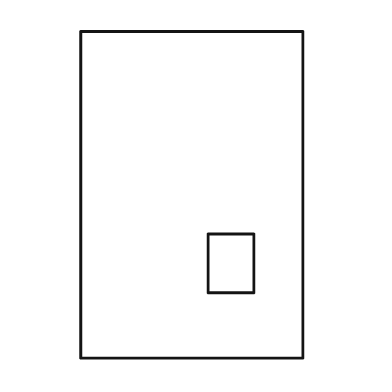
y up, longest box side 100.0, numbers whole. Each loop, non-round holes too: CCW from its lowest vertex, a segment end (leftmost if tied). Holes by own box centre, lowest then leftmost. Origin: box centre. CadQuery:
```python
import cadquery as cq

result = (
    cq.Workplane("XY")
    .moveTo(-34.0, -50.0)
    .lineTo(34.0, -50.0)
    .lineTo(34.0, 50.0)
    .lineTo(-34.0, 50.0)
    .close()
    .moveTo(5.0, -30.0)
    .lineTo(19.0, -30.0)
    .lineTo(19.0, -12.0)
    .lineTo(5.0, -12.0)
    .close()
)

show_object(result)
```